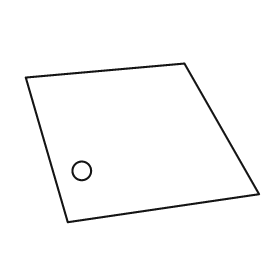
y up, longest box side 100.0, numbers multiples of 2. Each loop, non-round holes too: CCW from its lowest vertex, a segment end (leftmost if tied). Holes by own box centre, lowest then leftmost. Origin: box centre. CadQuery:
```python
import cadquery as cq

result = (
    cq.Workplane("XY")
    .moveTo(-32.0, -34.0)
    .lineTo(50.0, -22.0)
    .lineTo(18.0, 34.0)
    .lineTo(-50.0, 28.0)
    .close()
    .moveTo(-26.0, -12.0)
    .circle(4.0)
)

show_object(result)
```